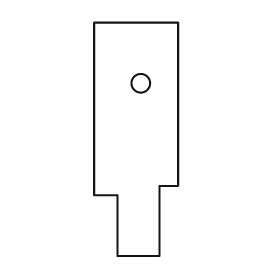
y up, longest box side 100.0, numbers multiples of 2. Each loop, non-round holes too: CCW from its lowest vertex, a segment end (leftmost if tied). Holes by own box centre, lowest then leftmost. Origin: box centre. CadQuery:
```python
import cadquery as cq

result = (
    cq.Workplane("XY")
    .moveTo(-8.0, -50.0)
    .lineTo(10.0, -50.0)
    .lineTo(10.0, -20.0)
    .lineTo(18.0, -20.0)
    .lineTo(18.0, 50.0)
    .lineTo(-18.0, 50.0)
    .lineTo(-18.0, -24.0)
    .lineTo(-8.0, -24.0)
    .close()
    .moveTo(2.0, 24.0)
    .circle(4.0)
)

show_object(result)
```